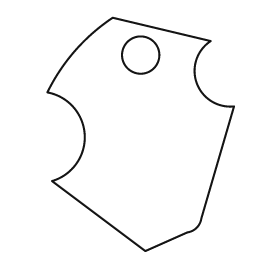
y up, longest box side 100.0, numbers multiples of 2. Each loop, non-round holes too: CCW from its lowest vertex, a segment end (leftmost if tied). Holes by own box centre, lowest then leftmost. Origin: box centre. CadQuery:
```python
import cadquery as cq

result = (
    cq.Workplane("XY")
    .moveTo(2.0, -50.0)
    .lineTo(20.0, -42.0)
    .threePointArc((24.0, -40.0), (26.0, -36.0))
    .lineTo(40.0, 12.0)
    .threePointArc((24.0, 22.0), (30.0, 40.0))
    .lineTo(-12.0, 50.0)
    .threePointArc((-28.0, 36.0), (-40.0, 18.0))
    .threePointArc((-24.0, 0.0), (-38.0, -20.0))
    .close()
    .moveTo(0.0, 34.0)
    .circle(8.0)
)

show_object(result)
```